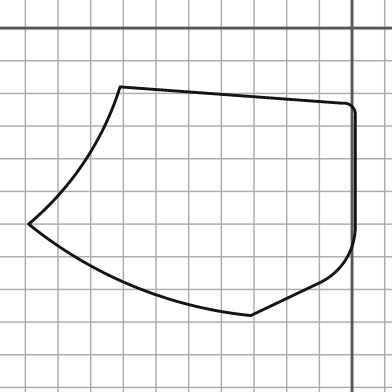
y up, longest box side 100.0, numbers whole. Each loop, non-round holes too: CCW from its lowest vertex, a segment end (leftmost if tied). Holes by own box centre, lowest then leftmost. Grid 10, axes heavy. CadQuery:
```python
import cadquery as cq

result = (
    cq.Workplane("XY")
    .moveTo(-31.0, -88.0)
    .lineTo(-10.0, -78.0)
    .threePointArc((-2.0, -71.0), (1.0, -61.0))
    .lineTo(1.0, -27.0)
    .threePointArc((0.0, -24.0), (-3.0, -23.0))
    .lineTo(-71.0, -18.0)
    .threePointArc((-82.0, -41.0), (-99.0, -60.0))
    .threePointArc((-67.0, -79.0), (-31.0, -88.0))
    .close()
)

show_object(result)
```